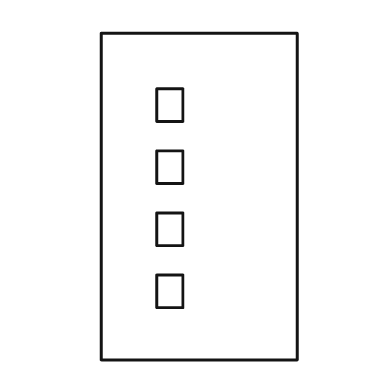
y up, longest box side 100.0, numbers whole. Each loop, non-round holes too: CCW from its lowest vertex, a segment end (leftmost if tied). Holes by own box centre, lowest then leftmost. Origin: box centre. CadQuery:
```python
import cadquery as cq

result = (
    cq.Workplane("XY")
    .moveTo(-30.0, -50.0)
    .lineTo(30.0, -50.0)
    .lineTo(30.0, 50.0)
    .lineTo(-30.0, 50.0)
    .close()
    .moveTo(-13.0, -34.0)
    .lineTo(-5.0, -34.0)
    .lineTo(-5.0, -24.0)
    .lineTo(-13.0, -24.0)
    .close()
    .moveTo(-13.0, -15.0)
    .lineTo(-5.0, -15.0)
    .lineTo(-5.0, -5.0)
    .lineTo(-13.0, -5.0)
    .close()
    .moveTo(-13.0, 4.0)
    .lineTo(-5.0, 4.0)
    .lineTo(-5.0, 14.0)
    .lineTo(-13.0, 14.0)
    .close()
    .moveTo(-13.0, 23.0)
    .lineTo(-5.0, 23.0)
    .lineTo(-5.0, 33.0)
    .lineTo(-13.0, 33.0)
    .close()
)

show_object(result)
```